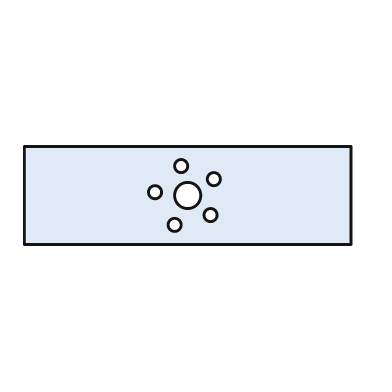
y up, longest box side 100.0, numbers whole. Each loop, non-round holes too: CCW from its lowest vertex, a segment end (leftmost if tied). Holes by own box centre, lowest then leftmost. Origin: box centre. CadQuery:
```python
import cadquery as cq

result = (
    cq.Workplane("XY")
    .moveTo(-50.0, -15.0)
    .lineTo(50.0, -15.0)
    .lineTo(50.0, 15.0)
    .lineTo(-50.0, 15.0)
    .close()
    .moveTo(-4.0, -9.0)
    .circle(2.0)
    .moveTo(7.0, -6.0)
    .circle(2.0)
    .moveTo(0.0, 0.0)
    .circle(4.0)
    .moveTo(-10.0, 1.0)
    .circle(2.0)
    .moveTo(8.0, 5.0)
    .circle(2.0)
    .moveTo(-2.0, 9.0)
    .circle(2.0)
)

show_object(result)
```